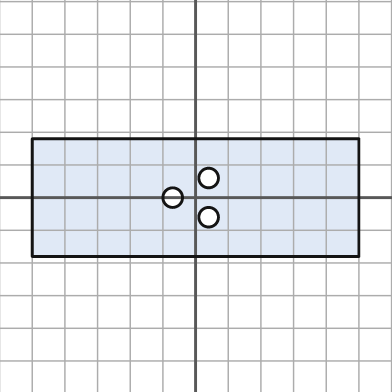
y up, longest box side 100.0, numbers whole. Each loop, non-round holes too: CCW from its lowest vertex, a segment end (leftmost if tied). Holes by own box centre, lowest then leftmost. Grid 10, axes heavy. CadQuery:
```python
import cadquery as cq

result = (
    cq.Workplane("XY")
    .moveTo(-50.0, -18.0)
    .lineTo(50.0, -18.0)
    .lineTo(50.0, 18.0)
    .lineTo(-50.0, 18.0)
    .close()
    .moveTo(4.0, -6.0)
    .circle(3.0)
    .moveTo(-7.0, 0.0)
    .circle(3.0)
    .moveTo(4.0, 6.0)
    .circle(3.0)
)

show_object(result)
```